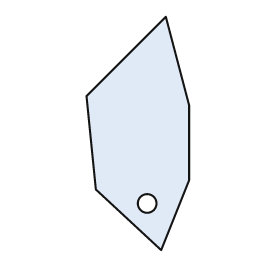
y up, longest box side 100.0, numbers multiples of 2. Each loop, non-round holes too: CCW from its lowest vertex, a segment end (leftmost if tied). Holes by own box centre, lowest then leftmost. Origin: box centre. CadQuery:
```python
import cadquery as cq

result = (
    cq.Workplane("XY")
    .moveTo(10.0, -50.0)
    .lineTo(22.0, -20.0)
    .lineTo(22.0, 12.0)
    .lineTo(12.0, 50.0)
    .lineTo(-22.0, 16.0)
    .lineTo(-18.0, -24.0)
    .close()
    .moveTo(4.0, -30.0)
    .circle(4.0)
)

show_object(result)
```